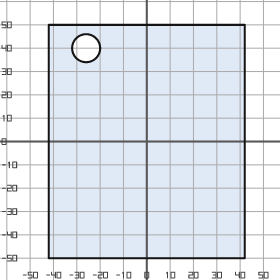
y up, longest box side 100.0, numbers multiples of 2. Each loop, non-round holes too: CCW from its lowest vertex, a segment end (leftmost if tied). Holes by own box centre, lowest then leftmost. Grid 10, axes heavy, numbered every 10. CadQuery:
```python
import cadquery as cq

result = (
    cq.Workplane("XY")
    .moveTo(-42.0, -50.0)
    .lineTo(42.0, -50.0)
    .lineTo(42.0, 50.0)
    .lineTo(-42.0, 50.0)
    .close()
    .moveTo(-26.0, 40.0)
    .circle(6.0)
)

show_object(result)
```